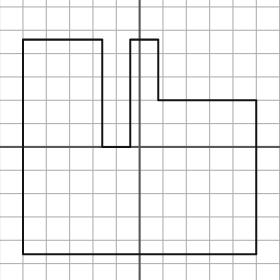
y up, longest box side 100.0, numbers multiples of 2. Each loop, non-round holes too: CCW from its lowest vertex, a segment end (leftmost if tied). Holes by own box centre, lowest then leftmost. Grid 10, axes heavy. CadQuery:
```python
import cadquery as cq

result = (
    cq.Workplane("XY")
    .moveTo(-50.0, -46.0)
    .lineTo(50.0, -46.0)
    .lineTo(50.0, 20.0)
    .lineTo(8.0, 20.0)
    .lineTo(8.0, 46.0)
    .lineTo(-4.0, 46.0)
    .lineTo(-4.0, 0.0)
    .lineTo(-16.0, 0.0)
    .lineTo(-16.0, 46.0)
    .lineTo(-50.0, 46.0)
    .close()
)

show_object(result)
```